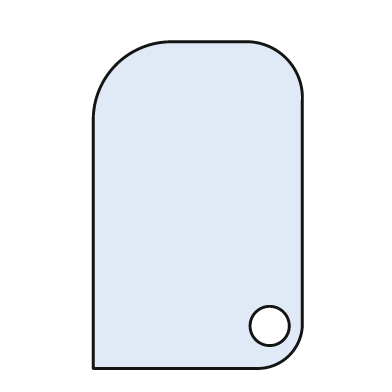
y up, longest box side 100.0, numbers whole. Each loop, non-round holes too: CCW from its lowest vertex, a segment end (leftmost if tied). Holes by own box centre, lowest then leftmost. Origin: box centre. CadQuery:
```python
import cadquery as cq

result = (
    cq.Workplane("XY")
    .moveTo(-32.0, -50.0)
    .lineTo(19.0, -50.0)
    .threePointArc((28.0, -46.0), (32.0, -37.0))
    .lineTo(32.0, 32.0)
    .threePointArc((27.0, 45.0), (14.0, 50.0))
    .lineTo(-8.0, 50.0)
    .threePointArc((-25.0, 43.0), (-32.0, 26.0))
    .close()
    .moveTo(22.0, -37.0)
    .circle(6.0)
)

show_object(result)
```